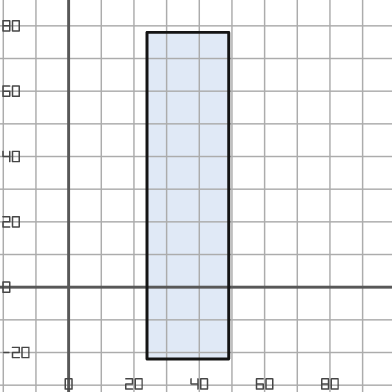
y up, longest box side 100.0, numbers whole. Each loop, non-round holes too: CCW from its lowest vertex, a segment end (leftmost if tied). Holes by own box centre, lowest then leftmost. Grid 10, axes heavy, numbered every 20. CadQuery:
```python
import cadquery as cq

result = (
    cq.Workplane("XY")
    .moveTo(24.0, -22.0)
    .lineTo(49.0, -22.0)
    .lineTo(49.0, 78.0)
    .lineTo(24.0, 78.0)
    .close()
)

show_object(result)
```